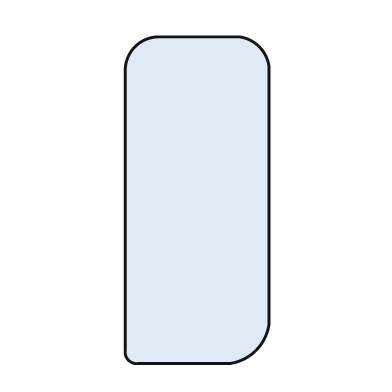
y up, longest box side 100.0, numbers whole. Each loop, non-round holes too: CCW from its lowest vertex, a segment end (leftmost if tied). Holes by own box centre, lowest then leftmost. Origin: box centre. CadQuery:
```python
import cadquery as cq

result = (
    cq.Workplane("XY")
    .moveTo(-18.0, -50.0)
    .lineTo(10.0, -50.0)
    .threePointArc((18.0, -46.0), (22.0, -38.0))
    .lineTo(22.0, 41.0)
    .threePointArc((19.0, 47.0), (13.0, 50.0))
    .lineTo(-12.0, 50.0)
    .threePointArc((-19.0, 47.0), (-22.0, 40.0))
    .lineTo(-22.0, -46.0)
    .threePointArc((-21.0, -49.0), (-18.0, -50.0))
    .close()
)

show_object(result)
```